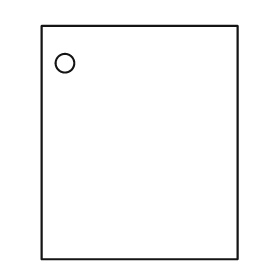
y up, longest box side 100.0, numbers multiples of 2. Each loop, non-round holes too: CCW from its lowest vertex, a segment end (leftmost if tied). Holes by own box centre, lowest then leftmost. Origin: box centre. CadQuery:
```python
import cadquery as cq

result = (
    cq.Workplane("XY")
    .moveTo(-42.0, -50.0)
    .lineTo(42.0, -50.0)
    .lineTo(42.0, 50.0)
    .lineTo(-42.0, 50.0)
    .close()
    .moveTo(-32.0, 34.0)
    .circle(4.0)
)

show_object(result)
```